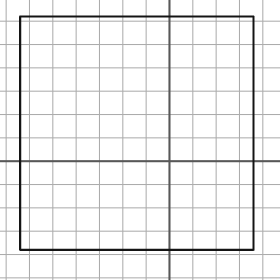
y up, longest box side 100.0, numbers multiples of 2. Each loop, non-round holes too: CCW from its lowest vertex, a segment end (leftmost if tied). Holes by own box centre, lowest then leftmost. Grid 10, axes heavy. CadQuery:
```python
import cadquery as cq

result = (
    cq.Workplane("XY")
    .moveTo(-64.0, -38.0)
    .lineTo(36.0, -38.0)
    .lineTo(36.0, 62.0)
    .lineTo(-64.0, 62.0)
    .close()
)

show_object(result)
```